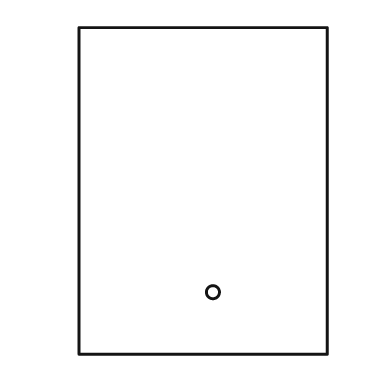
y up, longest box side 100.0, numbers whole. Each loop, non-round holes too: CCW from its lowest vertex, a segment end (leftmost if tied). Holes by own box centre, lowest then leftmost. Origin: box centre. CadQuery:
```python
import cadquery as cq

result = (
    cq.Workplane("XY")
    .moveTo(-38.0, -50.0)
    .lineTo(38.0, -50.0)
    .lineTo(38.0, 50.0)
    .lineTo(-38.0, 50.0)
    .close()
    .moveTo(3.0, -31.0)
    .circle(2.0)
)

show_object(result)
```